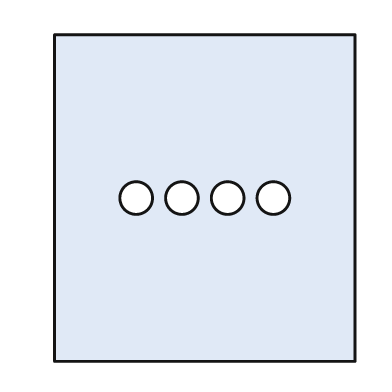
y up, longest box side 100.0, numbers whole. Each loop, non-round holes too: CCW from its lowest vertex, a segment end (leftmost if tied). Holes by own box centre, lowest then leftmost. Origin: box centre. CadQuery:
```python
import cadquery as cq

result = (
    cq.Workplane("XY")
    .moveTo(-46.0, -50.0)
    .lineTo(46.0, -50.0)
    .lineTo(46.0, 50.0)
    .lineTo(-46.0, 50.0)
    .close()
    .moveTo(-21.0, 0.0)
    .circle(5.0)
    .moveTo(-7.0, 0.0)
    .circle(5.0)
    .moveTo(7.0, 0.0)
    .circle(5.0)
    .moveTo(21.0, 0.0)
    .circle(5.0)
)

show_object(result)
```